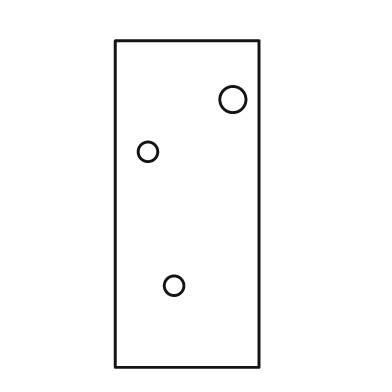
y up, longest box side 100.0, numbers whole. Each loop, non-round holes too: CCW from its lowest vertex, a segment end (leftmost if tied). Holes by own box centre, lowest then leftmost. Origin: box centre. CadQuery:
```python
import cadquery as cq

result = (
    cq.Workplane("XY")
    .moveTo(-22.0, -50.0)
    .lineTo(22.0, -50.0)
    .lineTo(22.0, 50.0)
    .lineTo(-22.0, 50.0)
    .close()
    .moveTo(-4.0, -25.0)
    .circle(3.0)
    .moveTo(-12.0, 16.0)
    .circle(3.0)
    .moveTo(14.0, 32.0)
    .circle(4.0)
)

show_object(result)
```